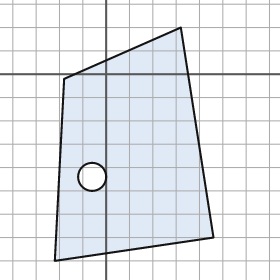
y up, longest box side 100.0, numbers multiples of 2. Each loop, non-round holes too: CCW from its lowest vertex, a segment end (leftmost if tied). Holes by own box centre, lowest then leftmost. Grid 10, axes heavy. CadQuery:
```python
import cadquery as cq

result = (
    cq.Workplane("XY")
    .moveTo(-22.0, -80.0)
    .lineTo(46.0, -70.0)
    .lineTo(32.0, 20.0)
    .lineTo(-18.0, -2.0)
    .close()
    .moveTo(-6.0, -44.0)
    .circle(6.0)
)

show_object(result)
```